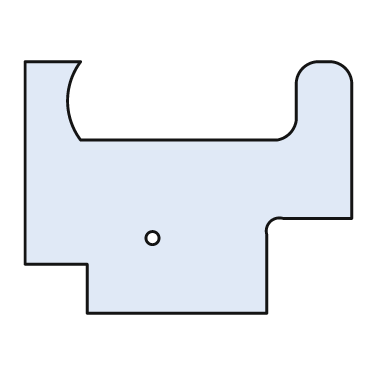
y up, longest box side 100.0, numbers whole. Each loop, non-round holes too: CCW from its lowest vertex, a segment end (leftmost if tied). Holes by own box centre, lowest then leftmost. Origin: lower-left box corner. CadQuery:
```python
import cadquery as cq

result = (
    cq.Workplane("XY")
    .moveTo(19.0, 0.0)
    .lineTo(74.0, 0.0)
    .lineTo(74.0, 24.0)
    .threePointArc((75.0, 28.0), (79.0, 29.0))
    .lineTo(100.0, 29.0)
    .lineTo(100.0, 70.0)
    .threePointArc((98.0, 75.0), (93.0, 77.0))
    .lineTo(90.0, 77.0)
    .threePointArc((85.0, 75.0), (83.0, 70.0))
    .lineTo(83.0, 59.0)
    .threePointArc((81.0, 55.0), (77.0, 53.0))
    .lineTo(17.0, 53.0)
    .threePointArc((13.0, 65.0), (17.0, 77.0))
    .lineTo(0.0, 77.0)
    .lineTo(0.0, 15.0)
    .lineTo(19.0, 15.0)
    .close()
    .moveTo(39.0, 23.0)
    .circle(2.0)
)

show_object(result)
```